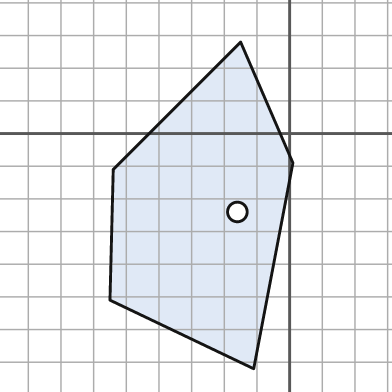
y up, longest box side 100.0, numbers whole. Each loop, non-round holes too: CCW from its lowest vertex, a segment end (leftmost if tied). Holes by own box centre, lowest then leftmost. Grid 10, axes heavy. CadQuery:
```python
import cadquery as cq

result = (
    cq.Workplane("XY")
    .moveTo(-11.0, -72.0)
    .lineTo(1.0, -9.0)
    .lineTo(-15.0, 28.0)
    .lineTo(-54.0, -11.0)
    .lineTo(-55.0, -51.0)
    .close()
    .moveTo(-16.0, -24.0)
    .circle(3.0)
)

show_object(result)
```